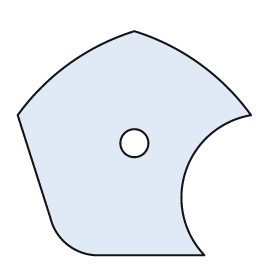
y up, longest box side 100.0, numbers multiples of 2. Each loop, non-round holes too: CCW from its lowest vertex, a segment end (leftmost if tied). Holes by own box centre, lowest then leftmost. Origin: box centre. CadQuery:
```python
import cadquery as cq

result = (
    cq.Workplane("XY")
    .moveTo(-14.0, -48.0)
    .lineTo(30.0, -48.0)
    .threePointArc((22.0, -12.0), (50.0, 12.0))
    .threePointArc((28.0, 34.0), (0.0, 48.0))
    .threePointArc((-28.0, 34.0), (-50.0, 12.0))
    .lineTo(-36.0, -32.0)
    .threePointArc((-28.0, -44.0), (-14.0, -48.0))
    .close()
    .moveTo(0.0, 0.0)
    .circle(6.0)
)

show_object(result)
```